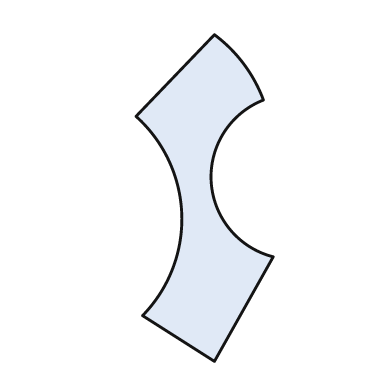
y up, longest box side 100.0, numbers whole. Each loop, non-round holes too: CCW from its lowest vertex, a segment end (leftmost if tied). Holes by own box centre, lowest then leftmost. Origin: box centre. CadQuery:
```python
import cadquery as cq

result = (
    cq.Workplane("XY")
    .moveTo(3.0, -50.0)
    .lineTo(21.0, -18.0)
    .threePointArc((2.0, 5.0), (18.0, 30.0))
    .threePointArc((12.0, 41.0), (3.0, 50.0))
    .lineTo(-21.0, 25.0)
    .threePointArc((-7.0, -5.0), (-19.0, -36.0))
    .close()
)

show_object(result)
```